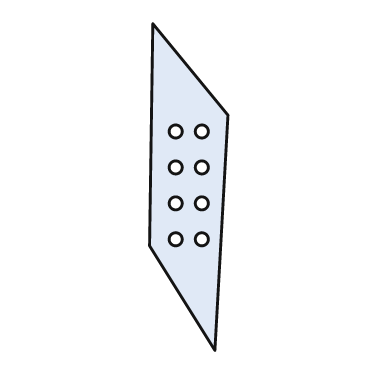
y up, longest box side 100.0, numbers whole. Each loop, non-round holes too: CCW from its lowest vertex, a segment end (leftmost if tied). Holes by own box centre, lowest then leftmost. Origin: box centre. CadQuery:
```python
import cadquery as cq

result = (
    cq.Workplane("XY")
    .moveTo(8.0, -50.0)
    .lineTo(12.0, 22.0)
    .lineTo(-11.0, 50.0)
    .lineTo(-12.0, -18.0)
    .close()
    .moveTo(-4.0, -16.0)
    .circle(2.0)
    .moveTo(4.0, -16.0)
    .circle(2.0)
    .moveTo(-4.0, -5.0)
    .circle(2.0)
    .moveTo(4.0, -5.0)
    .circle(2.0)
    .moveTo(-4.0, 6.0)
    .circle(2.0)
    .moveTo(4.0, 6.0)
    .circle(2.0)
    .moveTo(-4.0, 17.0)
    .circle(2.0)
    .moveTo(4.0, 17.0)
    .circle(2.0)
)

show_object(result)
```